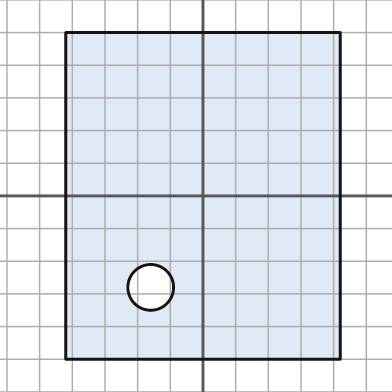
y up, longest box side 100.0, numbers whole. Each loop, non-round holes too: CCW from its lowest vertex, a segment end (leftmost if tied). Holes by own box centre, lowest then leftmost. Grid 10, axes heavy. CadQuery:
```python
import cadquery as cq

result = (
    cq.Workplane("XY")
    .moveTo(-42.0, -50.0)
    .lineTo(42.0, -50.0)
    .lineTo(42.0, 50.0)
    .lineTo(-42.0, 50.0)
    .close()
    .moveTo(-16.0, -28.0)
    .circle(7.0)
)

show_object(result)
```